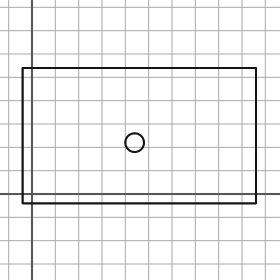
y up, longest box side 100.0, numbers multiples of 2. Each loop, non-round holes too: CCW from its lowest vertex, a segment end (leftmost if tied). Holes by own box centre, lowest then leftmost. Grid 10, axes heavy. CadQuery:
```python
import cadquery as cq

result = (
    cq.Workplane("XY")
    .moveTo(-4.0, -4.0)
    .lineTo(96.0, -4.0)
    .lineTo(96.0, 54.0)
    .lineTo(-4.0, 54.0)
    .close()
    .moveTo(44.0, 22.0)
    .circle(4.0)
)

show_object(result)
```